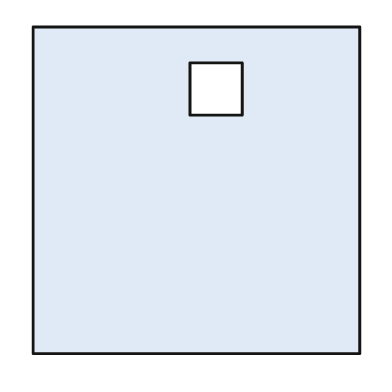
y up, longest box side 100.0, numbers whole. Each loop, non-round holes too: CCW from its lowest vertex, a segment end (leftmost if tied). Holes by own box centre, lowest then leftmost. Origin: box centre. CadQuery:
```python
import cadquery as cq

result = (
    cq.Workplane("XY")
    .moveTo(-50.0, -50.0)
    .lineTo(50.0, -50.0)
    .lineTo(50.0, 50.0)
    .lineTo(-50.0, 50.0)
    .close()
    .moveTo(-2.0, 23.0)
    .lineTo(14.0, 23.0)
    .lineTo(14.0, 39.0)
    .lineTo(-2.0, 39.0)
    .close()
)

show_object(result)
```